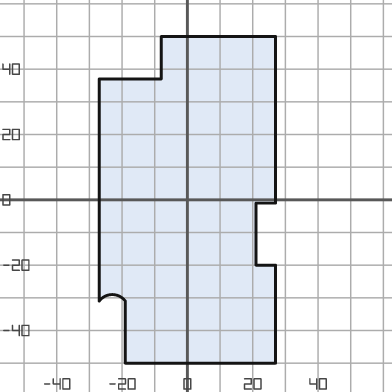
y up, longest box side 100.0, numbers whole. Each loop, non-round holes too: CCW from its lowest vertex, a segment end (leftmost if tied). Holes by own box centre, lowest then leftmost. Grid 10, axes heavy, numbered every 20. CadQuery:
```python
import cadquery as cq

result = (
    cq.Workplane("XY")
    .moveTo(-19.0, -50.0)
    .lineTo(27.0, -50.0)
    .lineTo(27.0, -20.0)
    .lineTo(21.0, -20.0)
    .lineTo(21.0, -1.0)
    .lineTo(27.0, -1.0)
    .lineTo(27.0, 50.0)
    .lineTo(-8.0, 50.0)
    .lineTo(-8.0, 37.0)
    .lineTo(-27.0, 37.0)
    .lineTo(-27.0, -31.0)
    .threePointArc((-23.0, -29.0), (-19.0, -31.0))
    .close()
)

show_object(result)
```